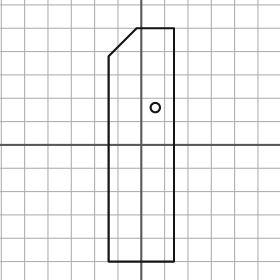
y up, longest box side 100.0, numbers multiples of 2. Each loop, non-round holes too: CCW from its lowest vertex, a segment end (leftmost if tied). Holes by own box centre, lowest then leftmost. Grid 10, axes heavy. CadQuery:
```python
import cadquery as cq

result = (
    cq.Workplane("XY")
    .moveTo(-14.0, -50.0)
    .lineTo(14.0, -50.0)
    .lineTo(14.0, 50.0)
    .lineTo(-2.0, 50.0)
    .lineTo(-14.0, 38.0)
    .close()
    .moveTo(6.0, 16.0)
    .circle(2.0)
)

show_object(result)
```